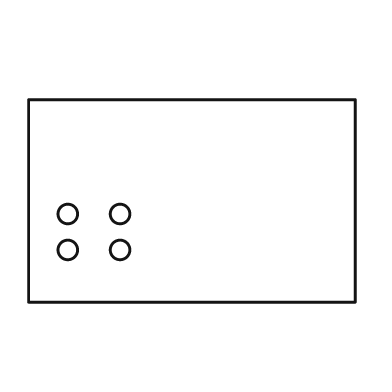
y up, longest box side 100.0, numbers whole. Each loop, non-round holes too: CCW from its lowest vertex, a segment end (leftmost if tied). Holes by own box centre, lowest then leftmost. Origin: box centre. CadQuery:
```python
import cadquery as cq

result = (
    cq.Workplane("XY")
    .moveTo(-50.0, -31.0)
    .lineTo(50.0, -31.0)
    .lineTo(50.0, 31.0)
    .lineTo(-50.0, 31.0)
    .close()
    .moveTo(-38.0, -15.0)
    .circle(3.0)
    .moveTo(-22.0, -15.0)
    .circle(3.0)
    .moveTo(-38.0, -4.0)
    .circle(3.0)
    .moveTo(-22.0, -4.0)
    .circle(3.0)
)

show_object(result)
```